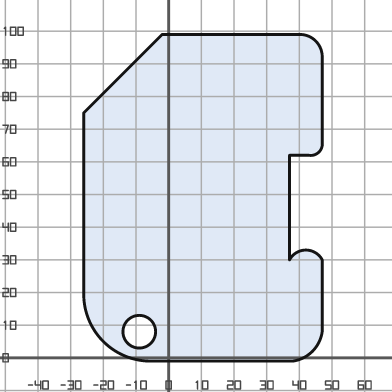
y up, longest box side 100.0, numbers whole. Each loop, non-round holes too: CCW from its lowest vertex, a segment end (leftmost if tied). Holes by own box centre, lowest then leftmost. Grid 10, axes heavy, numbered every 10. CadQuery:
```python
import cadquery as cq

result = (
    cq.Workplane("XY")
    .moveTo(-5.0, -1.0)
    .lineTo(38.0, -1.0)
    .threePointArc((44.0, 2.0), (47.0, 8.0))
    .lineTo(47.0, 30.0)
    .threePointArc((42.0, 33.0), (37.0, 30.0))
    .lineTo(37.0, 62.0)
    .lineTo(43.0, 62.0)
    .threePointArc((46.0, 63.0), (47.0, 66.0))
    .lineTo(47.0, 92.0)
    .threePointArc((45.0, 97.0), (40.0, 99.0))
    .lineTo(-2.0, 99.0)
    .lineTo(-26.0, 75.0)
    .lineTo(-26.0, 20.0)
    .threePointArc((-20.0, 5.0), (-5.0, -1.0))
    .close()
    .moveTo(-9.0, 8.0)
    .circle(5.0)
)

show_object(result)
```